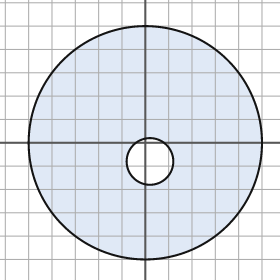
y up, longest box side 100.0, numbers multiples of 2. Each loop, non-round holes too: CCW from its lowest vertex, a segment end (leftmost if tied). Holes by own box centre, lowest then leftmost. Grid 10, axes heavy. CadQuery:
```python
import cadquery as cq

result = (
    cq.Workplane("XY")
    .moveTo(0.0, 0.0)
    .circle(50.0)
    .moveTo(2.0, -8.0)
    .circle(10.0)
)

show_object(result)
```